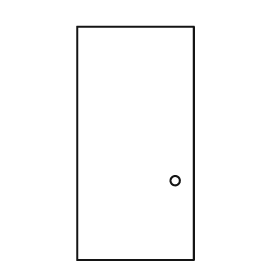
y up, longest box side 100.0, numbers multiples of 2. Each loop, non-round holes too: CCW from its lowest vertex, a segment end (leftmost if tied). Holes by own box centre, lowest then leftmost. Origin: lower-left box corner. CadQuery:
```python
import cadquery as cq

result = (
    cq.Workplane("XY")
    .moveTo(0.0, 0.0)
    .lineTo(50.0, 0.0)
    .lineTo(50.0, 100.0)
    .lineTo(0.0, 100.0)
    .close()
    .moveTo(42.0, 34.0)
    .circle(2.0)
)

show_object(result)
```